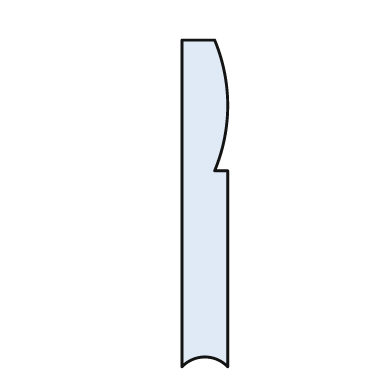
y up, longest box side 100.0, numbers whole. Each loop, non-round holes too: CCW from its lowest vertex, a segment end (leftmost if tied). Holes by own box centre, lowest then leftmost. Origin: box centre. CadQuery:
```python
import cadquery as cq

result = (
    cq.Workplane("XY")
    .moveTo(-7.0, -50.0)
    .threePointArc((0.0, -47.0), (7.0, -50.0))
    .lineTo(7.0, 10.0)
    .lineTo(3.0, 10.0)
    .threePointArc((7.0, 30.0), (3.0, 50.0))
    .lineTo(-7.0, 50.0)
    .close()
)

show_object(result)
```